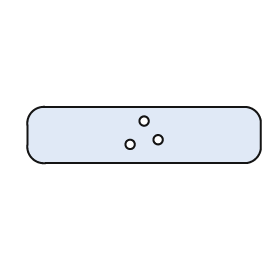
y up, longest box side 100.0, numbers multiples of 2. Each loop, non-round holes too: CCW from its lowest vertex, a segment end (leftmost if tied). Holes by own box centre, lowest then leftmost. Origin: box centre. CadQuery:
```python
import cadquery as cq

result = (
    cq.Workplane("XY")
    .moveTo(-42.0, -12.0)
    .lineTo(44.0, -12.0)
    .threePointArc((48.0, -10.0), (50.0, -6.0))
    .lineTo(50.0, 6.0)
    .threePointArc((48.0, 10.0), (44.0, 12.0))
    .lineTo(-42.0, 12.0)
    .threePointArc((-48.0, 10.0), (-50.0, 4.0))
    .lineTo(-50.0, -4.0)
    .threePointArc((-48.0, -10.0), (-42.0, -12.0))
    .close()
    .moveTo(-6.0, -4.0)
    .circle(2.0)
    .moveTo(6.0, -2.0)
    .circle(2.0)
    .moveTo(0.0, 6.0)
    .circle(2.0)
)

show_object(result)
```